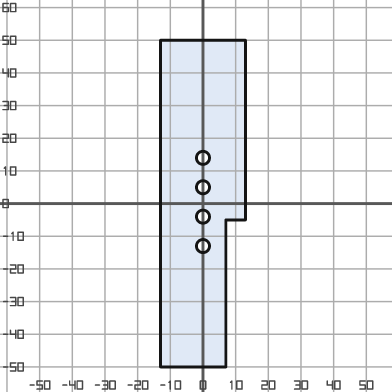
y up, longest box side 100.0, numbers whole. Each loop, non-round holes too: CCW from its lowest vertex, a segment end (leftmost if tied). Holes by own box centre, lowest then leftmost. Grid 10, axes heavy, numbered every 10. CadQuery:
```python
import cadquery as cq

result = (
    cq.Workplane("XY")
    .moveTo(-13.0, -50.0)
    .lineTo(7.0, -50.0)
    .lineTo(7.0, -5.0)
    .lineTo(13.0, -5.0)
    .lineTo(13.0, 50.0)
    .lineTo(-13.0, 50.0)
    .close()
    .moveTo(0.0, -13.0)
    .circle(2.0)
    .moveTo(0.0, -4.0)
    .circle(2.0)
    .moveTo(0.0, 5.0)
    .circle(2.0)
    .moveTo(0.0, 14.0)
    .circle(2.0)
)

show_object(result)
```